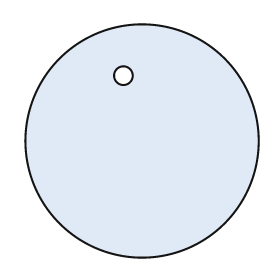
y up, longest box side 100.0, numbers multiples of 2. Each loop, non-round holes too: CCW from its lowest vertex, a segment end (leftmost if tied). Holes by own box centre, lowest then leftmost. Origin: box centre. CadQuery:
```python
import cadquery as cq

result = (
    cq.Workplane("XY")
    .moveTo(0.0, 0.0)
    .circle(50.0)
    .moveTo(-8.0, 28.0)
    .circle(4.0)
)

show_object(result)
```